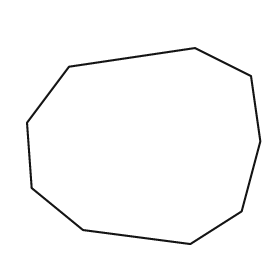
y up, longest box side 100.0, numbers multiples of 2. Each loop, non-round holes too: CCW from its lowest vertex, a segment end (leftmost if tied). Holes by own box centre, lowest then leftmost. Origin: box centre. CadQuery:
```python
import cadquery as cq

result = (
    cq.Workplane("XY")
    .moveTo(20.0, -42.0)
    .lineTo(42.0, -28.0)
    .lineTo(50.0, 2.0)
    .lineTo(46.0, 30.0)
    .lineTo(22.0, 42.0)
    .lineTo(-32.0, 34.0)
    .lineTo(-50.0, 10.0)
    .lineTo(-48.0, -18.0)
    .lineTo(-26.0, -36.0)
    .close()
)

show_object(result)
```